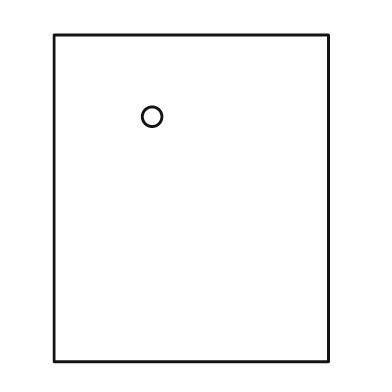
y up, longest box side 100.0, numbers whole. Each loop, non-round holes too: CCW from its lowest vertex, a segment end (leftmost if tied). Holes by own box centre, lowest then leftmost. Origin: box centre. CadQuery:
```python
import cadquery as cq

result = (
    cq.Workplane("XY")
    .moveTo(-42.0, -50.0)
    .lineTo(42.0, -50.0)
    .lineTo(42.0, 50.0)
    .lineTo(-42.0, 50.0)
    .close()
    .moveTo(-12.0, 25.0)
    .circle(3.0)
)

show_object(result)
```